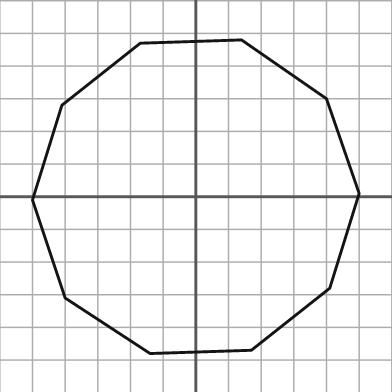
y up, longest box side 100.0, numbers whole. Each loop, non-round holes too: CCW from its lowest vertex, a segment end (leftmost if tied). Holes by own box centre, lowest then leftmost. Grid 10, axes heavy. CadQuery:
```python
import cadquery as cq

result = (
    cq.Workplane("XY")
    .moveTo(-14.0, -48.0)
    .lineTo(17.0, -47.0)
    .lineTo(41.0, -28.0)
    .lineTo(50.0, 1.0)
    .lineTo(40.0, 30.0)
    .lineTo(14.0, 48.0)
    .lineTo(-17.0, 47.0)
    .lineTo(-41.0, 28.0)
    .lineTo(-50.0, -1.0)
    .lineTo(-40.0, -31.0)
    .close()
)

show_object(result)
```